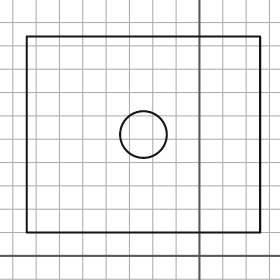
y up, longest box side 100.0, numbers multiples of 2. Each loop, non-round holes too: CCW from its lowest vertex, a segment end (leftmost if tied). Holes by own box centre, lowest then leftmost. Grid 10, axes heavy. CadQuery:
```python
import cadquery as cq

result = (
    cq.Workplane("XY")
    .moveTo(-74.0, 10.0)
    .lineTo(26.0, 10.0)
    .lineTo(26.0, 94.0)
    .lineTo(-74.0, 94.0)
    .close()
    .moveTo(-24.0, 52.0)
    .circle(10.0)
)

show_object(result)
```